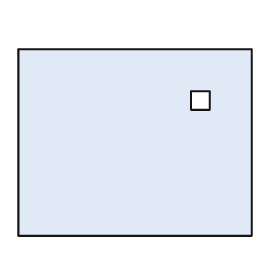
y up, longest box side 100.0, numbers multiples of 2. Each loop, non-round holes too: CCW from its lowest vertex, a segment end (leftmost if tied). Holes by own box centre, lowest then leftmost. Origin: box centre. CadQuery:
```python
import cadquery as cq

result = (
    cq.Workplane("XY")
    .moveTo(-50.0, -40.0)
    .lineTo(50.0, -40.0)
    .lineTo(50.0, 40.0)
    .lineTo(-50.0, 40.0)
    .close()
    .moveTo(24.0, 14.0)
    .lineTo(32.0, 14.0)
    .lineTo(32.0, 22.0)
    .lineTo(24.0, 22.0)
    .close()
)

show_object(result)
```